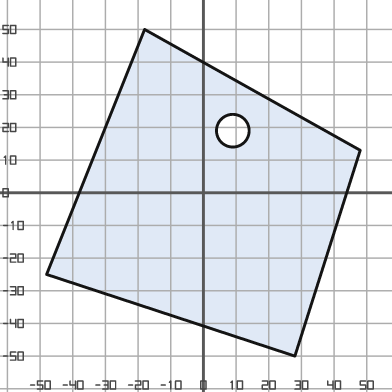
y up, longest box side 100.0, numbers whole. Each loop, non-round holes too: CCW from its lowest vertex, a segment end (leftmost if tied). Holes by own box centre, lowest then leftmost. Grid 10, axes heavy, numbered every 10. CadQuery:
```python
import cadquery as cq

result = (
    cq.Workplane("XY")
    .moveTo(28.0, -50.0)
    .lineTo(48.0, 13.0)
    .lineTo(-18.0, 50.0)
    .lineTo(-48.0, -25.0)
    .close()
    .moveTo(9.0, 19.0)
    .circle(5.0)
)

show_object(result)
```